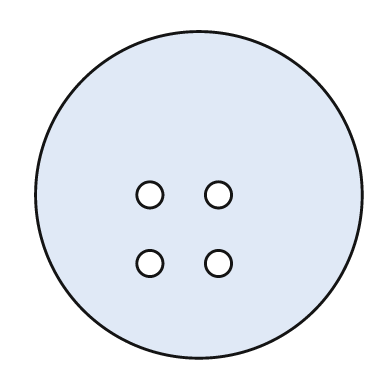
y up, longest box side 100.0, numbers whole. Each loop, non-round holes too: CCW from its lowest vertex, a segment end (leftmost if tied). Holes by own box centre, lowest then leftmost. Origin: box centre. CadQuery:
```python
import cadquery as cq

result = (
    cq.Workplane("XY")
    .moveTo(0.0, 0.0)
    .circle(50.0)
    .moveTo(-15.0, -21.0)
    .circle(4.0)
    .moveTo(6.0, -21.0)
    .circle(4.0)
    .moveTo(-15.0, 0.0)
    .circle(4.0)
    .moveTo(6.0, 0.0)
    .circle(4.0)
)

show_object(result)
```